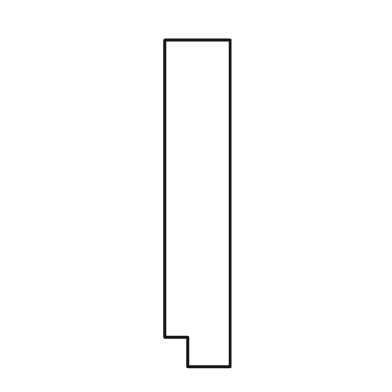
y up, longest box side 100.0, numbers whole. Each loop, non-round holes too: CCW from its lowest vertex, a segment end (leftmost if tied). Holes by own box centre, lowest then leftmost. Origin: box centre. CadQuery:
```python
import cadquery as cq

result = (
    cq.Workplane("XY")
    .moveTo(-3.0, -50.0)
    .lineTo(10.0, -50.0)
    .lineTo(10.0, 50.0)
    .lineTo(-10.0, 50.0)
    .lineTo(-10.0, -41.0)
    .lineTo(-3.0, -41.0)
    .close()
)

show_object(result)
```